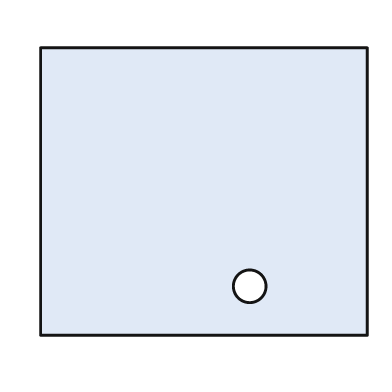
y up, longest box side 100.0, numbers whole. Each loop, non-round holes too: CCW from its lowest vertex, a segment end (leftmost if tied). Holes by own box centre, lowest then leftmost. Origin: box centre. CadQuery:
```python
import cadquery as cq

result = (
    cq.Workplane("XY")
    .moveTo(-50.0, -44.0)
    .lineTo(50.0, -44.0)
    .lineTo(50.0, 44.0)
    .lineTo(-50.0, 44.0)
    .close()
    .moveTo(14.0, -29.0)
    .circle(5.0)
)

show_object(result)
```